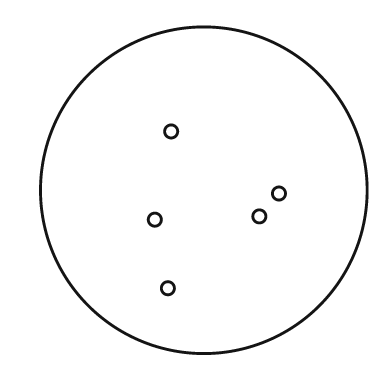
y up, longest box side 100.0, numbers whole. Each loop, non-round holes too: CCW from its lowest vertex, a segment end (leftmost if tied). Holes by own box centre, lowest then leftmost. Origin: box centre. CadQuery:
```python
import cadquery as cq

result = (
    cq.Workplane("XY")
    .moveTo(0.0, 0.0)
    .circle(50.0)
    .moveTo(-11.0, -30.0)
    .circle(2.0)
    .moveTo(-15.0, -9.0)
    .circle(2.0)
    .moveTo(17.0, -8.0)
    .circle(2.0)
    .moveTo(23.0, -1.0)
    .circle(2.0)
    .moveTo(-10.0, 18.0)
    .circle(2.0)
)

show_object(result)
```